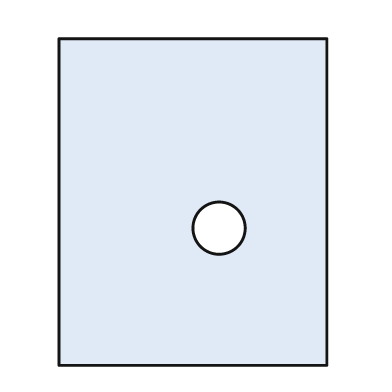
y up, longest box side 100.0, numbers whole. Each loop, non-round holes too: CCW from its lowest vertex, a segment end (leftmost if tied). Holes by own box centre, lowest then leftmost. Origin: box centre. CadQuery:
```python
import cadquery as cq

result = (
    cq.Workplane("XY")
    .moveTo(-41.0, -50.0)
    .lineTo(41.0, -50.0)
    .lineTo(41.0, 50.0)
    .lineTo(-41.0, 50.0)
    .close()
    .moveTo(8.0, -8.0)
    .circle(8.0)
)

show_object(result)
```